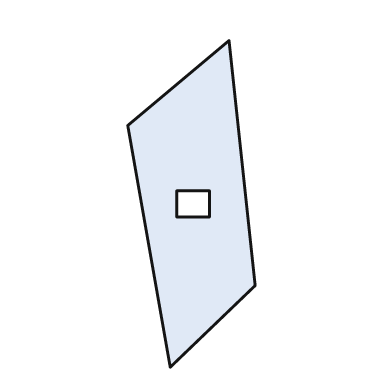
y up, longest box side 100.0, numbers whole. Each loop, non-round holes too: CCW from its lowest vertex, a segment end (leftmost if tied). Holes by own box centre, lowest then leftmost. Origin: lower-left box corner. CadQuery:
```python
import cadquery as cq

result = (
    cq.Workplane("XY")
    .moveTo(13.0, 0.0)
    .lineTo(39.0, 25.0)
    .lineTo(31.0, 100.0)
    .lineTo(0.0, 74.0)
    .close()
    .moveTo(15.0, 46.0)
    .lineTo(25.0, 46.0)
    .lineTo(25.0, 54.0)
    .lineTo(15.0, 54.0)
    .close()
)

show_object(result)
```